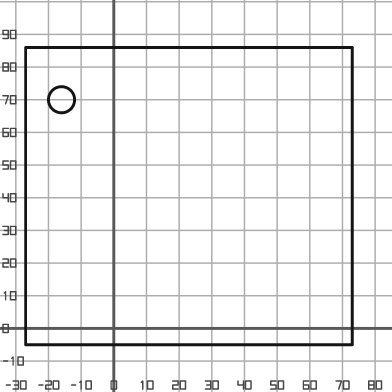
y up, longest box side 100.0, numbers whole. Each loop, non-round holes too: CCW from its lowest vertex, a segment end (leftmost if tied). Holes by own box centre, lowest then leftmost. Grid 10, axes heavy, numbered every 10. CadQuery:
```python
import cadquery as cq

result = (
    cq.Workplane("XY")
    .moveTo(-27.0, -5.0)
    .lineTo(73.0, -5.0)
    .lineTo(73.0, 86.0)
    .lineTo(-27.0, 86.0)
    .close()
    .moveTo(-16.0, 70.0)
    .circle(4.0)
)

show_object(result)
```